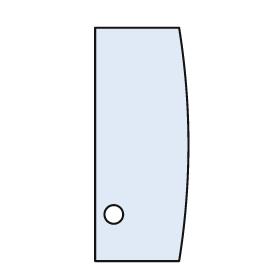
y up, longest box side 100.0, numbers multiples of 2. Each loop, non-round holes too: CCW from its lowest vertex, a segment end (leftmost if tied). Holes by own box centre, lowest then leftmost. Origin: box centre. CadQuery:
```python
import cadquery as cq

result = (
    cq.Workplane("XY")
    .moveTo(-20.0, -50.0)
    .lineTo(16.0, -50.0)
    .threePointArc((20.0, 0.0), (16.0, 50.0))
    .lineTo(-20.0, 50.0)
    .close()
    .moveTo(-12.0, -30.0)
    .circle(4.0)
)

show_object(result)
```